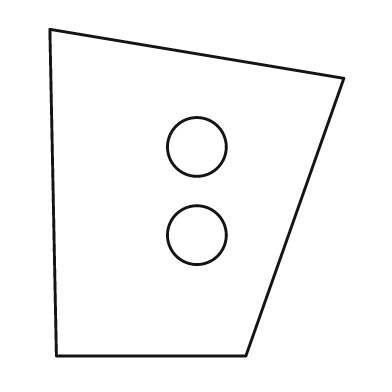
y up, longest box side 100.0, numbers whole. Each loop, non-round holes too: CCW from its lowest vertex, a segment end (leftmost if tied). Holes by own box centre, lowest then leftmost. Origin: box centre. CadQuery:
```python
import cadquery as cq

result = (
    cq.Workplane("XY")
    .moveTo(-43.0, -50.0)
    .lineTo(15.0, -50.0)
    .lineTo(45.0, 35.0)
    .lineTo(-45.0, 50.0)
    .close()
    .moveTo(0.0, -13.0)
    .circle(9.0)
    .moveTo(0.0, 14.0)
    .circle(9.0)
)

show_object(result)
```